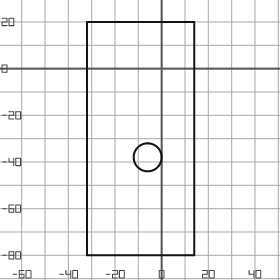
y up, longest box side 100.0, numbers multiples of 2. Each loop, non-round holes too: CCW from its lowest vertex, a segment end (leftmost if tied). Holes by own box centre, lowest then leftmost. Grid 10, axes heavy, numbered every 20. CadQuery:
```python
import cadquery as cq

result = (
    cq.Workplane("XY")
    .moveTo(-32.0, -80.0)
    .lineTo(14.0, -80.0)
    .lineTo(14.0, 20.0)
    .lineTo(-32.0, 20.0)
    .close()
    .moveTo(-6.0, -38.0)
    .circle(6.0)
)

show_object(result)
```